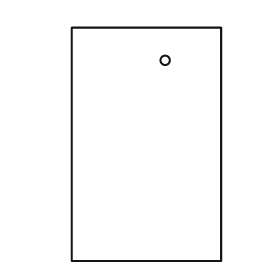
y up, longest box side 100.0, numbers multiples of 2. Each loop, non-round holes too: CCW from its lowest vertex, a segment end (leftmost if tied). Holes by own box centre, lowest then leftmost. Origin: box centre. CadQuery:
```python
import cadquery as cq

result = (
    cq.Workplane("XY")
    .moveTo(-32.0, -50.0)
    .lineTo(32.0, -50.0)
    .lineTo(32.0, 50.0)
    .lineTo(-32.0, 50.0)
    .close()
    .moveTo(8.0, 36.0)
    .circle(2.0)
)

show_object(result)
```